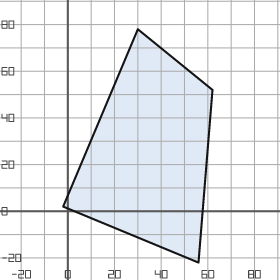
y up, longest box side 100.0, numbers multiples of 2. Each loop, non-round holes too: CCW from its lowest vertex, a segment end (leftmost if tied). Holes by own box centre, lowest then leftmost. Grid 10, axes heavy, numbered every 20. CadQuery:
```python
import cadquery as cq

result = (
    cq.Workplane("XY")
    .moveTo(56.0, -22.0)
    .lineTo(62.0, 52.0)
    .lineTo(30.0, 78.0)
    .lineTo(-2.0, 2.0)
    .close()
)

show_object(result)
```